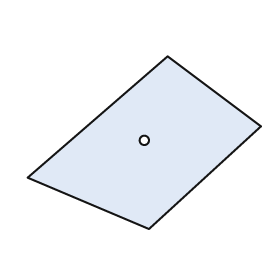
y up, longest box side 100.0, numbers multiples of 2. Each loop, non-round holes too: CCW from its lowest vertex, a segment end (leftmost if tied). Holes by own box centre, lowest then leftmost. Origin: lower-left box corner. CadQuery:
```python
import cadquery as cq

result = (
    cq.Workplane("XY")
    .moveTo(52.0, 0.0)
    .lineTo(100.0, 44.0)
    .lineTo(60.0, 74.0)
    .lineTo(0.0, 22.0)
    .close()
    .moveTo(50.0, 38.0)
    .circle(2.0)
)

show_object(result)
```